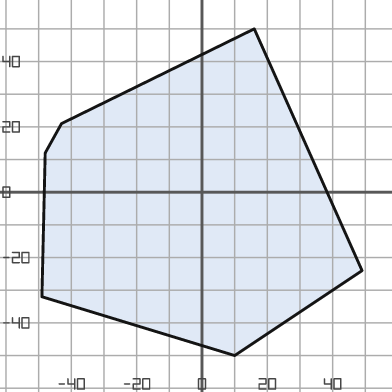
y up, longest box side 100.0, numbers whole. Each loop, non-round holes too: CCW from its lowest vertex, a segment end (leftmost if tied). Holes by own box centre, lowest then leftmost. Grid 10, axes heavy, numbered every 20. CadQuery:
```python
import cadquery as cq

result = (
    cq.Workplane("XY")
    .moveTo(10.0, -50.0)
    .lineTo(49.0, -24.0)
    .lineTo(16.0, 50.0)
    .lineTo(-43.0, 21.0)
    .lineTo(-48.0, 12.0)
    .lineTo(-49.0, -32.0)
    .close()
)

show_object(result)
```